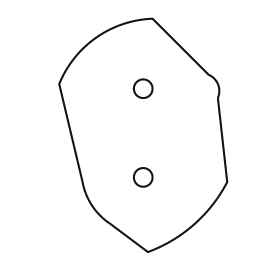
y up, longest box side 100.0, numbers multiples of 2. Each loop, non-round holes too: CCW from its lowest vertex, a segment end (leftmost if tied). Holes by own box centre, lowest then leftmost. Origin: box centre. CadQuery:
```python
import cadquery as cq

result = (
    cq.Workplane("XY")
    .moveTo(2.0, -50.0)
    .threePointArc((22.0, -38.0), (36.0, -20.0))
    .lineTo(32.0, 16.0)
    .threePointArc((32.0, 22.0), (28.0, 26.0))
    .lineTo(4.0, 50.0)
    .threePointArc((-20.0, 42.0), (-36.0, 22.0))
    .lineTo(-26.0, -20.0)
    .threePointArc((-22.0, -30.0), (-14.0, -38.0))
    .close()
    .moveTo(0.0, -18.0)
    .circle(4.0)
    .moveTo(0.0, 20.0)
    .circle(4.0)
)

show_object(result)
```